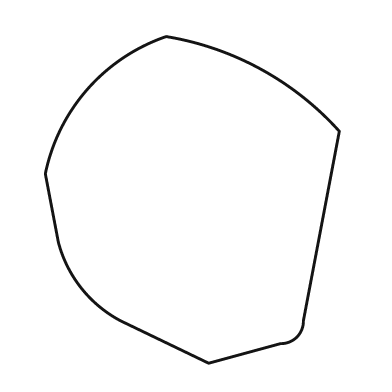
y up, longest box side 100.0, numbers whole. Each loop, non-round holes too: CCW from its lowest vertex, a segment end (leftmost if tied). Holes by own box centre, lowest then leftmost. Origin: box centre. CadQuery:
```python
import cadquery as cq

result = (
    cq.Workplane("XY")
    .moveTo(5.0, -50.0)
    .lineTo(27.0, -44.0)
    .threePointArc((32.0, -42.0), (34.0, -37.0))
    .lineTo(45.0, 21.0)
    .threePointArc((21.0, 40.0), (-8.0, 50.0))
    .threePointArc((-32.0, 34.0), (-45.0, 8.0))
    .lineTo(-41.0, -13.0)
    .threePointArc((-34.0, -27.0), (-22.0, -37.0))
    .close()
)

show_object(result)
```